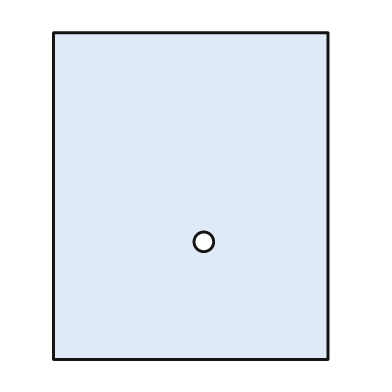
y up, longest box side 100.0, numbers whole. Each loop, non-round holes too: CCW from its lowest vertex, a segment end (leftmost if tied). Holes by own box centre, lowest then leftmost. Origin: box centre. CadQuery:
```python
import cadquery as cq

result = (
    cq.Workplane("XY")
    .moveTo(-42.0, -50.0)
    .lineTo(42.0, -50.0)
    .lineTo(42.0, 50.0)
    .lineTo(-42.0, 50.0)
    .close()
    .moveTo(4.0, -14.0)
    .circle(3.0)
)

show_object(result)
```